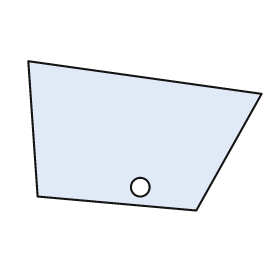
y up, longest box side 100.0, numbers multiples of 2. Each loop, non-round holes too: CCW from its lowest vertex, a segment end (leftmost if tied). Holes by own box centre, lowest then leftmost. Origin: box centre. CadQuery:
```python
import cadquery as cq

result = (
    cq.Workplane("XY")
    .moveTo(22.0, -32.0)
    .lineTo(50.0, 18.0)
    .lineTo(-50.0, 32.0)
    .lineTo(-46.0, -26.0)
    .close()
    .moveTo(-2.0, -22.0)
    .circle(4.0)
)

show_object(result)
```